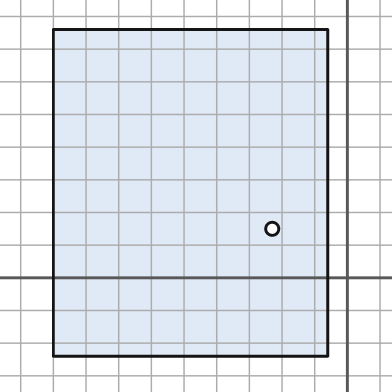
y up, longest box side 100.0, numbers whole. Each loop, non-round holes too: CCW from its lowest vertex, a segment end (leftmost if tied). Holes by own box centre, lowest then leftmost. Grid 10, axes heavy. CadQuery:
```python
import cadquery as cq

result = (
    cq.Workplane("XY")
    .moveTo(-90.0, -24.0)
    .lineTo(-6.0, -24.0)
    .lineTo(-6.0, 76.0)
    .lineTo(-90.0, 76.0)
    .close()
    .moveTo(-23.0, 15.0)
    .circle(2.0)
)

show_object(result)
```